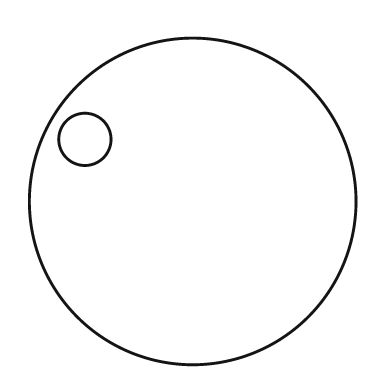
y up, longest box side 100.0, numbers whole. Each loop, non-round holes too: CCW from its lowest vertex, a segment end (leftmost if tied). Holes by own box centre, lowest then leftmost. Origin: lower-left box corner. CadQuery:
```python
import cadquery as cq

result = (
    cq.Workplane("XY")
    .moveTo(50.0, 50.0)
    .circle(50.0)
    .moveTo(17.0, 69.0)
    .circle(8.0)
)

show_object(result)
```